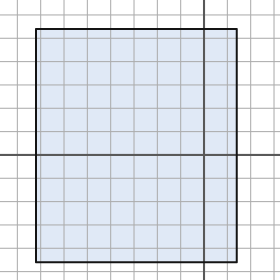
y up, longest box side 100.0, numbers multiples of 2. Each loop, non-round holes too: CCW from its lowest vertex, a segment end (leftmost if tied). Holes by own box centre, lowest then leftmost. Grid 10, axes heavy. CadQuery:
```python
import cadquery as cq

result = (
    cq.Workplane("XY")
    .moveTo(-72.0, -46.0)
    .lineTo(14.0, -46.0)
    .lineTo(14.0, 54.0)
    .lineTo(-72.0, 54.0)
    .close()
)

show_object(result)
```